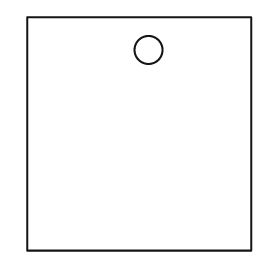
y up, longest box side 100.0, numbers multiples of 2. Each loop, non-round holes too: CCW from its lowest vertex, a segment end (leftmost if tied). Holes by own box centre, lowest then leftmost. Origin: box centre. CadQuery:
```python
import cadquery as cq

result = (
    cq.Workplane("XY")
    .moveTo(-48.0, -50.0)
    .lineTo(48.0, -50.0)
    .lineTo(48.0, 50.0)
    .lineTo(-48.0, 50.0)
    .close()
    .moveTo(4.0, 36.0)
    .circle(6.0)
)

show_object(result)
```